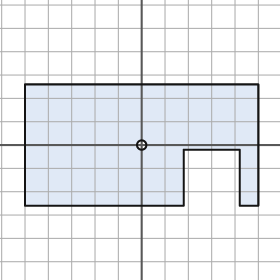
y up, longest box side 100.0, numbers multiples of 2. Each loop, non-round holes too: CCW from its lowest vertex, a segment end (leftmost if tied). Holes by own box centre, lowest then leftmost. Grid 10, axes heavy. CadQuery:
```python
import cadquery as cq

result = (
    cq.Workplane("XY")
    .moveTo(-50.0, -26.0)
    .lineTo(18.0, -26.0)
    .lineTo(18.0, -2.0)
    .lineTo(42.0, -2.0)
    .lineTo(42.0, -26.0)
    .lineTo(50.0, -26.0)
    .lineTo(50.0, 26.0)
    .lineTo(-50.0, 26.0)
    .close()
    .moveTo(0.0, 0.0)
    .circle(2.0)
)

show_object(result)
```